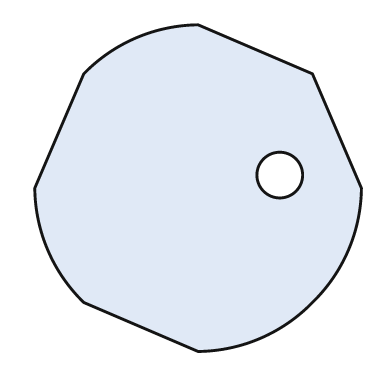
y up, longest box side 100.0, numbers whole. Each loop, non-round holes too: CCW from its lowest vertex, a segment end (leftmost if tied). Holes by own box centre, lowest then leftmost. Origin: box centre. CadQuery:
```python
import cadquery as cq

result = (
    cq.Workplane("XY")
    .moveTo(0.0, -50.0)
    .threePointArc((19.0, -46.0), (35.0, -35.0))
    .threePointArc((46.0, -19.0), (50.0, 0.0))
    .lineTo(35.0, 35.0)
    .lineTo(0.0, 50.0)
    .threePointArc((-19.0, 46.0), (-35.0, 35.0))
    .lineTo(-50.0, 0.0)
    .threePointArc((-46.0, -19.0), (-35.0, -35.0))
    .close()
    .moveTo(25.0, 4.0)
    .circle(7.0)
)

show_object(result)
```